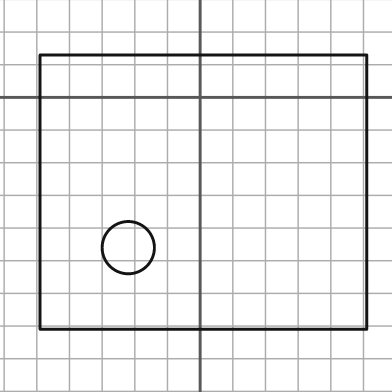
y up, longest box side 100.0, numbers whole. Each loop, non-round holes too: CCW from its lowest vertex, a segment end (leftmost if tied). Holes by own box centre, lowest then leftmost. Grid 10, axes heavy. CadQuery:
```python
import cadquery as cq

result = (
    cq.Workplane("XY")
    .moveTo(-49.0, -71.0)
    .lineTo(51.0, -71.0)
    .lineTo(51.0, 13.0)
    .lineTo(-49.0, 13.0)
    .close()
    .moveTo(-22.0, -46.0)
    .circle(8.0)
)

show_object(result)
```